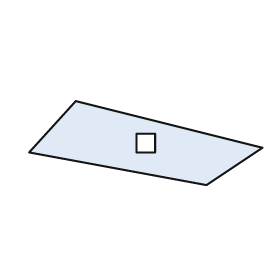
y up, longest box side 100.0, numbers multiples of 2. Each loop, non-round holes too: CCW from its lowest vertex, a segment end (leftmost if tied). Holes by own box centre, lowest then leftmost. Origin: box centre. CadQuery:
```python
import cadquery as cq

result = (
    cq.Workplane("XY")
    .moveTo(26.0, -18.0)
    .lineTo(50.0, -2.0)
    .lineTo(-30.0, 18.0)
    .lineTo(-50.0, -4.0)
    .close()
    .moveTo(-4.0, -4.0)
    .lineTo(4.0, -4.0)
    .lineTo(4.0, 4.0)
    .lineTo(-4.0, 4.0)
    .close()
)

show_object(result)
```